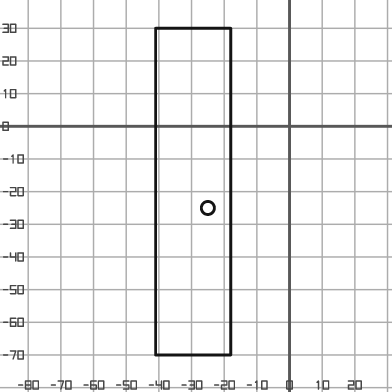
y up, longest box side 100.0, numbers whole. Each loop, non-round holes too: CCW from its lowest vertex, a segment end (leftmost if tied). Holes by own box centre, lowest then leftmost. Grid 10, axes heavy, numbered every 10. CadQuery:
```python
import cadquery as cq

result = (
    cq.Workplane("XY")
    .moveTo(-41.0, -70.0)
    .lineTo(-18.0, -70.0)
    .lineTo(-18.0, 30.0)
    .lineTo(-41.0, 30.0)
    .close()
    .moveTo(-25.0, -25.0)
    .circle(2.0)
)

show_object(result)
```